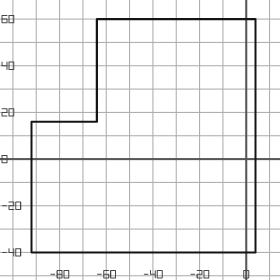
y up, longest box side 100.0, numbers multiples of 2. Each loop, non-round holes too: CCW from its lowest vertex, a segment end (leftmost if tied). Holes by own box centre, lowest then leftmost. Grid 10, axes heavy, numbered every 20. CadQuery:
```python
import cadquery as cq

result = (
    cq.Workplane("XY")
    .moveTo(-92.0, -40.0)
    .lineTo(4.0, -40.0)
    .lineTo(4.0, 60.0)
    .lineTo(-64.0, 60.0)
    .lineTo(-64.0, 16.0)
    .lineTo(-92.0, 16.0)
    .close()
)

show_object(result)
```